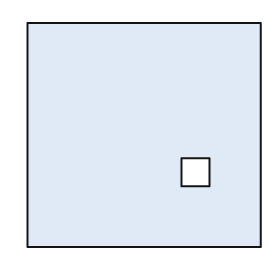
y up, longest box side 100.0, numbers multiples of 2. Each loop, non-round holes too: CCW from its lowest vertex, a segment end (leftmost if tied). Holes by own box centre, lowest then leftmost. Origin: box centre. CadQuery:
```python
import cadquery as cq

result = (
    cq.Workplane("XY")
    .moveTo(-50.0, -48.0)
    .lineTo(50.0, -48.0)
    .lineTo(50.0, 48.0)
    .lineTo(-50.0, 48.0)
    .close()
    .moveTo(16.0, -22.0)
    .lineTo(28.0, -22.0)
    .lineTo(28.0, -10.0)
    .lineTo(16.0, -10.0)
    .close()
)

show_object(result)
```